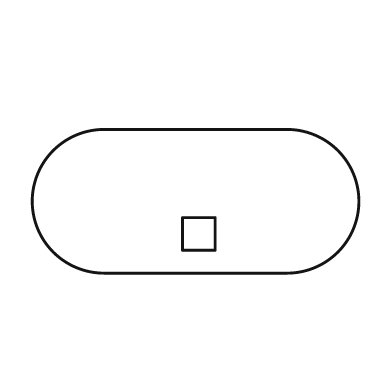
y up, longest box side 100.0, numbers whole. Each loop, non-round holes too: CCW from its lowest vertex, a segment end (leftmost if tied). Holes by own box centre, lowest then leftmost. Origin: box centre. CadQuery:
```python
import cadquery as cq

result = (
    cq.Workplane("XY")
    .moveTo(-28.0, -22.0)
    .lineTo(28.0, -22.0)
    .threePointArc((50.0, 0.0), (28.0, 22.0))
    .lineTo(-28.0, 22.0)
    .threePointArc((-50.0, 0.0), (-28.0, -22.0))
    .close()
    .moveTo(-4.0, -15.0)
    .lineTo(6.0, -15.0)
    .lineTo(6.0, -5.0)
    .lineTo(-4.0, -5.0)
    .close()
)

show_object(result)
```